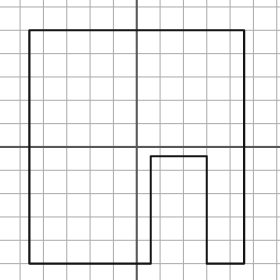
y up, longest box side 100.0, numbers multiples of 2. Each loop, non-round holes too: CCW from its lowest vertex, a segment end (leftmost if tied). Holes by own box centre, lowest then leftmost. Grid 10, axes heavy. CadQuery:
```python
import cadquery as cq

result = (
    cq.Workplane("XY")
    .moveTo(-46.0, -50.0)
    .lineTo(6.0, -50.0)
    .lineTo(6.0, -4.0)
    .lineTo(30.0, -4.0)
    .lineTo(30.0, -50.0)
    .lineTo(46.0, -50.0)
    .lineTo(46.0, 50.0)
    .lineTo(-46.0, 50.0)
    .close()
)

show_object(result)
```